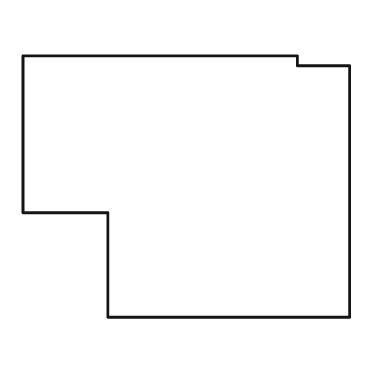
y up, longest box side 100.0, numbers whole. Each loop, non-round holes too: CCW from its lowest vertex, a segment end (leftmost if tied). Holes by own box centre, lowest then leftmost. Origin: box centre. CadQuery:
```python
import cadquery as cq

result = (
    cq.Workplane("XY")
    .moveTo(-24.0, -40.0)
    .lineTo(50.0, -40.0)
    .lineTo(50.0, 37.0)
    .lineTo(34.0, 37.0)
    .lineTo(34.0, 40.0)
    .lineTo(-50.0, 40.0)
    .lineTo(-50.0, -8.0)
    .lineTo(-24.0, -8.0)
    .close()
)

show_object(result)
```